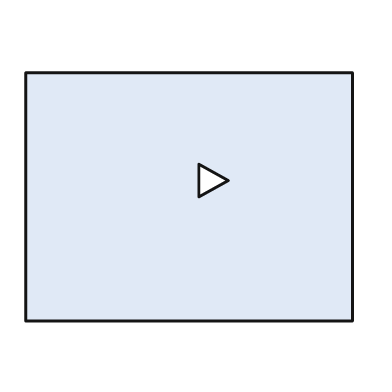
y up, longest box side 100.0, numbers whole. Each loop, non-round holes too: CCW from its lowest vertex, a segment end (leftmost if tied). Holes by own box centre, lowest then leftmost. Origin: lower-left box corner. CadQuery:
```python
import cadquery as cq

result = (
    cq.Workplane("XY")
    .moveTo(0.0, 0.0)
    .lineTo(100.0, 0.0)
    .lineTo(100.0, 76.0)
    .lineTo(0.0, 76.0)
    .close()
    .moveTo(53.0, 38.0)
    .lineTo(62.0, 43.0)
    .lineTo(53.0, 48.0)
    .close()
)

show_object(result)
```